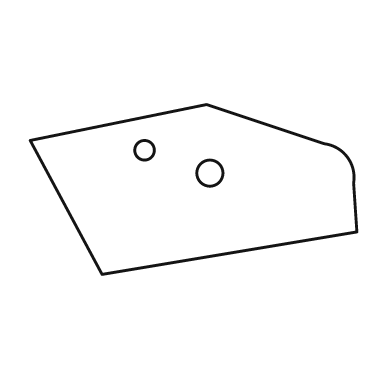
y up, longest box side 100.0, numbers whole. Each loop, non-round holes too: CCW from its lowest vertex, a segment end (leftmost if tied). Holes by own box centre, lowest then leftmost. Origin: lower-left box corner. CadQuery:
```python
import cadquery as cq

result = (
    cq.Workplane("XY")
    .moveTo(22.0, 0.0)
    .lineTo(100.0, 13.0)
    .lineTo(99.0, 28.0)
    .threePointArc((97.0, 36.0), (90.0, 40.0))
    .lineTo(54.0, 52.0)
    .lineTo(0.0, 41.0)
    .close()
    .moveTo(55.0, 31.0)
    .circle(4.0)
    .moveTo(35.0, 38.0)
    .circle(3.0)
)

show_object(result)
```